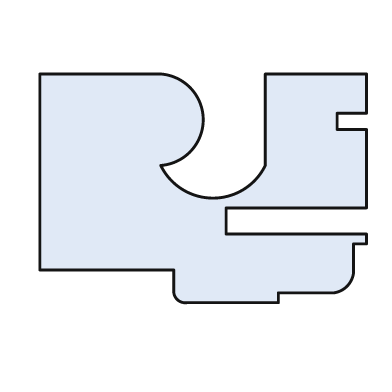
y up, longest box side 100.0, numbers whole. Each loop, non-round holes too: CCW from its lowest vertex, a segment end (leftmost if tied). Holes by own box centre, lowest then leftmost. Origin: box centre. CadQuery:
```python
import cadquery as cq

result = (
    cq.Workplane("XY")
    .moveTo(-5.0, -35.0)
    .lineTo(23.0, -35.0)
    .lineTo(23.0, -32.0)
    .lineTo(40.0, -32.0)
    .threePointArc((44.0, -30.0), (46.0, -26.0))
    .lineTo(46.0, -17.0)
    .lineTo(50.0, -17.0)
    .lineTo(50.0, -14.0)
    .lineTo(7.0, -14.0)
    .lineTo(7.0, -6.0)
    .lineTo(50.0, -6.0)
    .lineTo(50.0, 18.0)
    .lineTo(41.0, 18.0)
    .lineTo(41.0, 23.0)
    .lineTo(50.0, 23.0)
    .lineTo(50.0, 35.0)
    .lineTo(19.0, 35.0)
    .lineTo(19.0, 7.0)
    .threePointArc((3.0, -3.0), (-13.0, 7.0))
    .threePointArc((0.0, 21.0), (-13.0, 35.0))
    .lineTo(-50.0, 35.0)
    .lineTo(-50.0, -25.0)
    .lineTo(-9.0, -25.0)
    .lineTo(-9.0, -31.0)
    .threePointArc((-8.0, -34.0), (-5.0, -35.0))
    .close()
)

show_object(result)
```